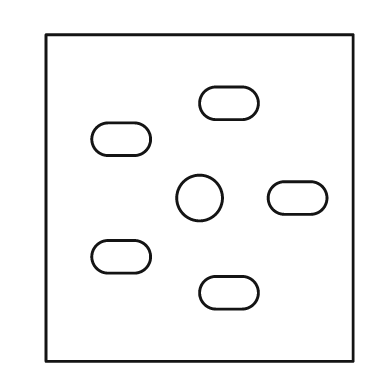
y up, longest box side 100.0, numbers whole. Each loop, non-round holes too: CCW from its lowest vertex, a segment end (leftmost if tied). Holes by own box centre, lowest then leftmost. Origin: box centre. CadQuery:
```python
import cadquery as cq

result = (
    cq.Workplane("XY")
    .moveTo(-47.0, -50.0)
    .lineTo(47.0, -50.0)
    .lineTo(47.0, 50.0)
    .lineTo(-47.0, 50.0)
    .close()
    .moveTo(5.0, -34.0)
    .lineTo(13.0, -34.0)
    .threePointArc((18.0, -29.0), (13.0, -24.0))
    .lineTo(5.0, -24.0)
    .threePointArc((0.0, -29.0), (5.0, -34.0))
    .close()
    .moveTo(-28.0, -23.0)
    .lineTo(-20.0, -23.0)
    .threePointArc((-15.0, -18.0), (-20.0, -13.0))
    .lineTo(-28.0, -13.0)
    .threePointArc((-33.0, -18.0), (-28.0, -23.0))
    .close()
    .moveTo(0.0, 0.0)
    .circle(7.0)
    .moveTo(26.0, -5.0)
    .lineTo(34.0, -5.0)
    .threePointArc((39.0, 0.0), (34.0, 5.0))
    .lineTo(26.0, 5.0)
    .threePointArc((21.0, 0.0), (26.0, -5.0))
    .close()
    .moveTo(-28.0, 13.0)
    .lineTo(-20.0, 13.0)
    .threePointArc((-15.0, 18.0), (-20.0, 23.0))
    .lineTo(-28.0, 23.0)
    .threePointArc((-33.0, 18.0), (-28.0, 13.0))
    .close()
    .moveTo(5.0, 24.0)
    .lineTo(13.0, 24.0)
    .threePointArc((18.0, 29.0), (13.0, 34.0))
    .lineTo(5.0, 34.0)
    .threePointArc((0.0, 29.0), (5.0, 24.0))
    .close()
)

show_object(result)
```